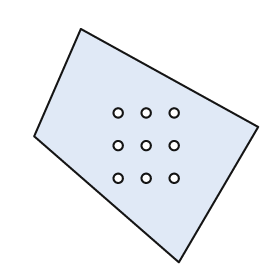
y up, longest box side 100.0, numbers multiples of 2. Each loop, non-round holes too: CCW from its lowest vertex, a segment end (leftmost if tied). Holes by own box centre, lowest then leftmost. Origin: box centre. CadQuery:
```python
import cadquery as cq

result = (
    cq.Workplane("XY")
    .moveTo(14.0, -50.0)
    .lineTo(48.0, 8.0)
    .lineTo(-28.0, 50.0)
    .lineTo(-48.0, 4.0)
    .close()
    .moveTo(-12.0, -14.0)
    .circle(2.0)
    .moveTo(0.0, -14.0)
    .circle(2.0)
    .moveTo(12.0, -14.0)
    .circle(2.0)
    .moveTo(-12.0, 0.0)
    .circle(2.0)
    .moveTo(0.0, 0.0)
    .circle(2.0)
    .moveTo(12.0, 0.0)
    .circle(2.0)
    .moveTo(-12.0, 14.0)
    .circle(2.0)
    .moveTo(0.0, 14.0)
    .circle(2.0)
    .moveTo(12.0, 14.0)
    .circle(2.0)
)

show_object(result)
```